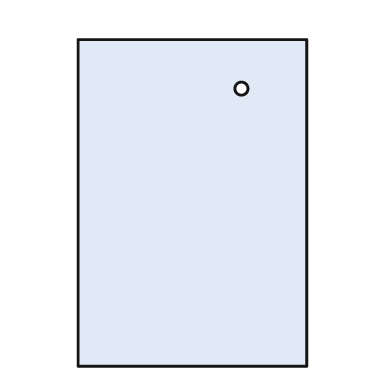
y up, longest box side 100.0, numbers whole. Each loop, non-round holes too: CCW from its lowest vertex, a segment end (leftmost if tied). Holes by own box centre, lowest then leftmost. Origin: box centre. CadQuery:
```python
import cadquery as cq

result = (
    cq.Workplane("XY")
    .moveTo(-35.0, -50.0)
    .lineTo(35.0, -50.0)
    .lineTo(35.0, 50.0)
    .lineTo(-35.0, 50.0)
    .close()
    .moveTo(15.0, 35.0)
    .circle(2.0)
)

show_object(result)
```